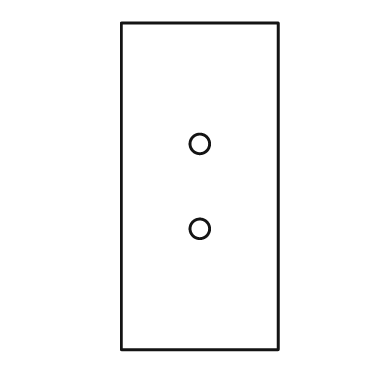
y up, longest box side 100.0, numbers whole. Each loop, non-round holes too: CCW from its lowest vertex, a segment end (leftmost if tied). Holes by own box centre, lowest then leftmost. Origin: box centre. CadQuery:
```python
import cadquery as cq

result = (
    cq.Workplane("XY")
    .moveTo(-24.0, -50.0)
    .lineTo(24.0, -50.0)
    .lineTo(24.0, 50.0)
    .lineTo(-24.0, 50.0)
    .close()
    .moveTo(0.0, -13.0)
    .circle(3.0)
    .moveTo(0.0, 13.0)
    .circle(3.0)
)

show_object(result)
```